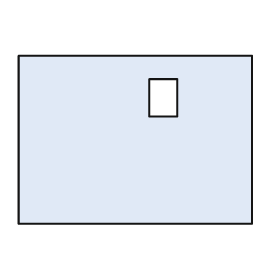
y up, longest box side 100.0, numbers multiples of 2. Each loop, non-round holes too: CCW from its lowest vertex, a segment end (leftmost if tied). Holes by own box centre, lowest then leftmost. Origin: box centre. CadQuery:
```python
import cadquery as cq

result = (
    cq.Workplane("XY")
    .moveTo(-50.0, -36.0)
    .lineTo(50.0, -36.0)
    .lineTo(50.0, 36.0)
    .lineTo(-50.0, 36.0)
    .close()
    .moveTo(6.0, 10.0)
    .lineTo(18.0, 10.0)
    .lineTo(18.0, 26.0)
    .lineTo(6.0, 26.0)
    .close()
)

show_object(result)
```